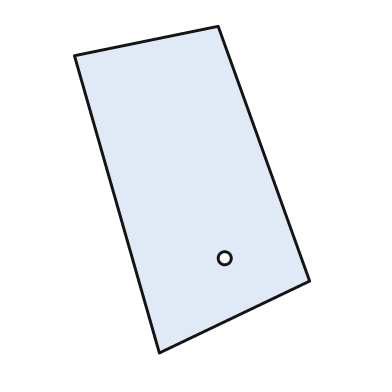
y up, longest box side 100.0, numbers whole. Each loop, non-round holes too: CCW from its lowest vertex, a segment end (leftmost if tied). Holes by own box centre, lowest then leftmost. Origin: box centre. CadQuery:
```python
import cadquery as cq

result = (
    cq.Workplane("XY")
    .moveTo(-10.0, -50.0)
    .lineTo(36.0, -28.0)
    .lineTo(8.0, 50.0)
    .lineTo(-36.0, 41.0)
    .close()
    .moveTo(10.0, -21.0)
    .circle(2.0)
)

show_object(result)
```